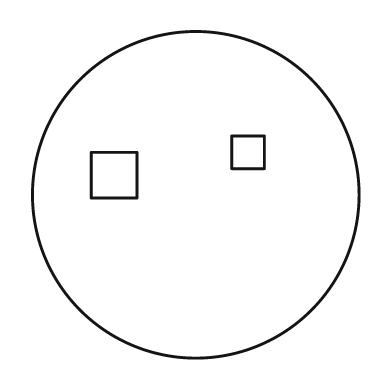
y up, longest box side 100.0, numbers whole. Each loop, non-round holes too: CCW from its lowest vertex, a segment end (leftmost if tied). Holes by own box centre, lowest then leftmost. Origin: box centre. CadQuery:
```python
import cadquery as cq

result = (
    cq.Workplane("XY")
    .moveTo(0.0, 0.0)
    .circle(50.0)
    .moveTo(-32.0, -1.0)
    .lineTo(-18.0, -1.0)
    .lineTo(-18.0, 13.0)
    .lineTo(-32.0, 13.0)
    .close()
    .moveTo(11.0, 8.0)
    .lineTo(21.0, 8.0)
    .lineTo(21.0, 18.0)
    .lineTo(11.0, 18.0)
    .close()
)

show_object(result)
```